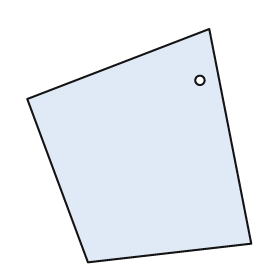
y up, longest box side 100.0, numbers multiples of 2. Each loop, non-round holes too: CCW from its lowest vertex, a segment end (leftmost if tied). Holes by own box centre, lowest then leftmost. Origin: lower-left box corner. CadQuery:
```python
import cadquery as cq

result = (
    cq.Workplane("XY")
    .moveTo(26.0, 0.0)
    .lineTo(96.0, 8.0)
    .lineTo(78.0, 100.0)
    .lineTo(0.0, 70.0)
    .close()
    .moveTo(74.0, 78.0)
    .circle(2.0)
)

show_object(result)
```